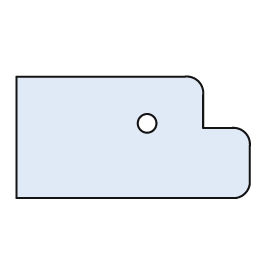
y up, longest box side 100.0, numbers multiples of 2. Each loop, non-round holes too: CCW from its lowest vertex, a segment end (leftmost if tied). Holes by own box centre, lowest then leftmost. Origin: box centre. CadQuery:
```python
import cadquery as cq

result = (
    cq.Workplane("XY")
    .moveTo(-50.0, -26.0)
    .lineTo(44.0, -26.0)
    .threePointArc((48.0, -24.0), (50.0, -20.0))
    .lineTo(50.0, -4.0)
    .threePointArc((48.0, 2.0), (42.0, 4.0))
    .lineTo(30.0, 4.0)
    .lineTo(30.0, 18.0)
    .threePointArc((28.0, 24.0), (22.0, 26.0))
    .lineTo(-50.0, 26.0)
    .close()
    .moveTo(6.0, 6.0)
    .circle(4.0)
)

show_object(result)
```